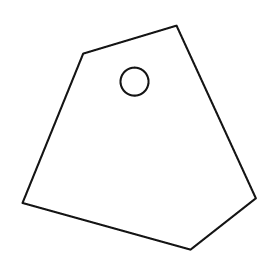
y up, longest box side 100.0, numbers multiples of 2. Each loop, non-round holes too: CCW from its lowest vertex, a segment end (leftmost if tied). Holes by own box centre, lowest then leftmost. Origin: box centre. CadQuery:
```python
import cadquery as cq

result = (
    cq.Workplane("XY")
    .moveTo(22.0, -48.0)
    .lineTo(50.0, -26.0)
    .lineTo(16.0, 48.0)
    .lineTo(-24.0, 36.0)
    .lineTo(-50.0, -28.0)
    .close()
    .moveTo(-2.0, 24.0)
    .circle(6.0)
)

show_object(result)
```